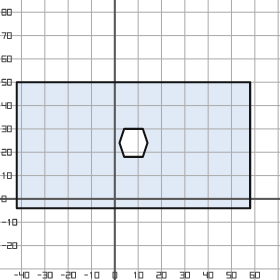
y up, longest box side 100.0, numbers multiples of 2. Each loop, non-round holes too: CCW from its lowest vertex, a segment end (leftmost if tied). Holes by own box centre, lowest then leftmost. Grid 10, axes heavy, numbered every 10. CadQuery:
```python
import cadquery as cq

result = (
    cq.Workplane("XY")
    .moveTo(-42.0, -4.0)
    .lineTo(58.0, -4.0)
    .lineTo(58.0, 50.0)
    .lineTo(-42.0, 50.0)
    .close()
    .moveTo(4.0, 18.0)
    .lineTo(12.0, 18.0)
    .lineTo(14.0, 24.0)
    .lineTo(12.0, 30.0)
    .lineTo(4.0, 30.0)
    .lineTo(2.0, 24.0)
    .close()
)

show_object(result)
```